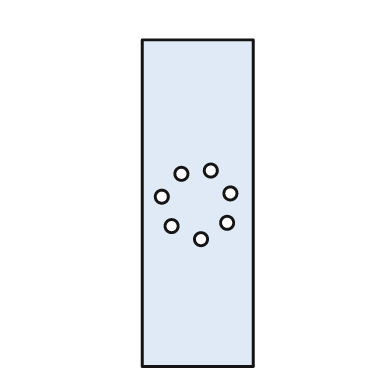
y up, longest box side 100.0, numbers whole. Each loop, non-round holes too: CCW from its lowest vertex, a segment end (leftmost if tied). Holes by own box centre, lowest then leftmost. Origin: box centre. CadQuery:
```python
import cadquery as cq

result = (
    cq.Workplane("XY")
    .moveTo(-17.0, -50.0)
    .lineTo(17.0, -50.0)
    .lineTo(17.0, 50.0)
    .lineTo(-17.0, 50.0)
    .close()
    .moveTo(1.0, -11.0)
    .circle(2.0)
    .moveTo(-8.0, -7.0)
    .circle(2.0)
    .moveTo(9.0, -6.0)
    .circle(2.0)
    .moveTo(-11.0, 2.0)
    .circle(2.0)
    .moveTo(10.0, 3.0)
    .circle(2.0)
    .moveTo(-5.0, 9.0)
    .circle(2.0)
    .moveTo(4.0, 10.0)
    .circle(2.0)
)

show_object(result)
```